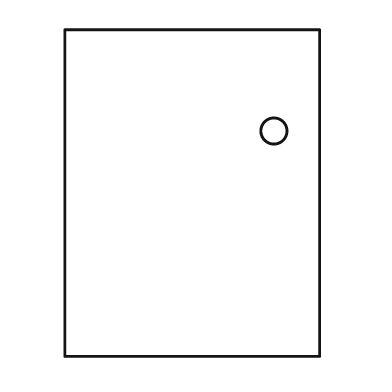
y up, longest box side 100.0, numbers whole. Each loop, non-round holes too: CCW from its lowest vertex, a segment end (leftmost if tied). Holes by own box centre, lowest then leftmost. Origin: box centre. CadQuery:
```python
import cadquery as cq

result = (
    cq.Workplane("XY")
    .moveTo(-39.0, -50.0)
    .lineTo(39.0, -50.0)
    .lineTo(39.0, 50.0)
    .lineTo(-39.0, 50.0)
    .close()
    .moveTo(25.0, 19.0)
    .circle(4.0)
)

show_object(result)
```